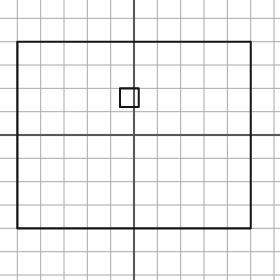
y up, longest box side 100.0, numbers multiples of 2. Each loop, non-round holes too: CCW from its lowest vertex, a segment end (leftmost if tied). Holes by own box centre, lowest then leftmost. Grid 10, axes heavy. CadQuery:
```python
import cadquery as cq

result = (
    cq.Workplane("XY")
    .moveTo(-50.0, -40.0)
    .lineTo(50.0, -40.0)
    .lineTo(50.0, 40.0)
    .lineTo(-50.0, 40.0)
    .close()
    .moveTo(-6.0, 12.0)
    .lineTo(2.0, 12.0)
    .lineTo(2.0, 20.0)
    .lineTo(-6.0, 20.0)
    .close()
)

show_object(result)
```